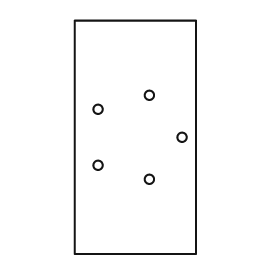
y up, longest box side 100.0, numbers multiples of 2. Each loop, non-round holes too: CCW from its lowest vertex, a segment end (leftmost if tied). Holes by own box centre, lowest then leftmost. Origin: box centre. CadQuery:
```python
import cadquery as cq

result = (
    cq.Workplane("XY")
    .moveTo(-26.0, -50.0)
    .lineTo(26.0, -50.0)
    .lineTo(26.0, 50.0)
    .lineTo(-26.0, 50.0)
    .close()
    .moveTo(6.0, -18.0)
    .circle(2.0)
    .moveTo(-16.0, -12.0)
    .circle(2.0)
    .moveTo(20.0, 0.0)
    .circle(2.0)
    .moveTo(-16.0, 12.0)
    .circle(2.0)
    .moveTo(6.0, 18.0)
    .circle(2.0)
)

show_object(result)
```